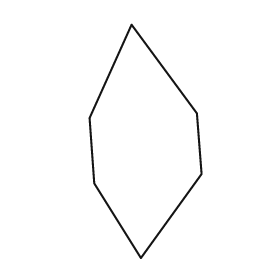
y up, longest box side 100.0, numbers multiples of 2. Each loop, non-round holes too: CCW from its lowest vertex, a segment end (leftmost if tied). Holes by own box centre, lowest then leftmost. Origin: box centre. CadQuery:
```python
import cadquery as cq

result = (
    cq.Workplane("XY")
    .moveTo(-2.0, -50.0)
    .lineTo(24.0, -14.0)
    .lineTo(22.0, 12.0)
    .lineTo(-6.0, 50.0)
    .lineTo(-24.0, 10.0)
    .lineTo(-22.0, -18.0)
    .close()
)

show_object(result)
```